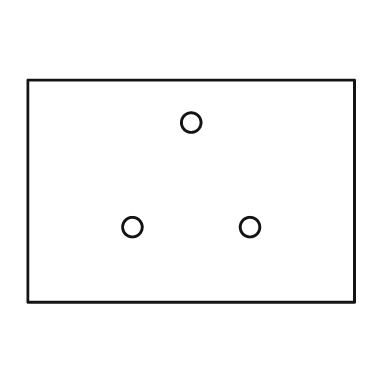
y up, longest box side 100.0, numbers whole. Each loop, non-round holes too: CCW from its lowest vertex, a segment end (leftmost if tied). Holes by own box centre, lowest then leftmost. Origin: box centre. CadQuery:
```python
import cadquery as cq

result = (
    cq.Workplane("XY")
    .moveTo(-50.0, -34.0)
    .lineTo(50.0, -34.0)
    .lineTo(50.0, 34.0)
    .lineTo(-50.0, 34.0)
    .close()
    .moveTo(-18.0, -11.0)
    .circle(3.0)
    .moveTo(18.0, -11.0)
    .circle(3.0)
    .moveTo(0.0, 21.0)
    .circle(3.0)
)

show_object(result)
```